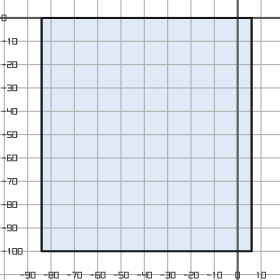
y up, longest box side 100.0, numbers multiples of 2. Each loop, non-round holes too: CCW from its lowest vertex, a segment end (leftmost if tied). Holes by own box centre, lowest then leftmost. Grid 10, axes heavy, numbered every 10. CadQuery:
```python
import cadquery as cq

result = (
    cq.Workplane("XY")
    .moveTo(-84.0, -100.0)
    .lineTo(6.0, -100.0)
    .lineTo(6.0, 0.0)
    .lineTo(-84.0, 0.0)
    .close()
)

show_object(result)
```